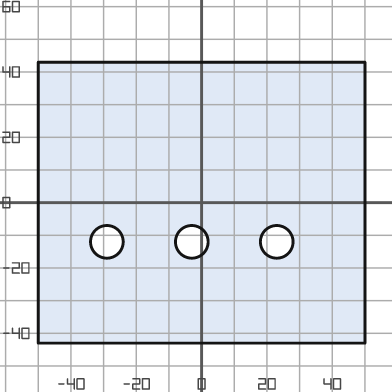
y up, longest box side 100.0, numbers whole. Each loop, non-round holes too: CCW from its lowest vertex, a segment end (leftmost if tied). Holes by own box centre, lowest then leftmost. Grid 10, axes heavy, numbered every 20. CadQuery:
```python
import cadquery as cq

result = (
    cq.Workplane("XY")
    .moveTo(-50.0, -43.0)
    .lineTo(50.0, -43.0)
    .lineTo(50.0, 43.0)
    .lineTo(-50.0, 43.0)
    .close()
    .moveTo(-29.0, -12.0)
    .circle(5.0)
    .moveTo(-3.0, -12.0)
    .circle(5.0)
    .moveTo(23.0, -12.0)
    .circle(5.0)
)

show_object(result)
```